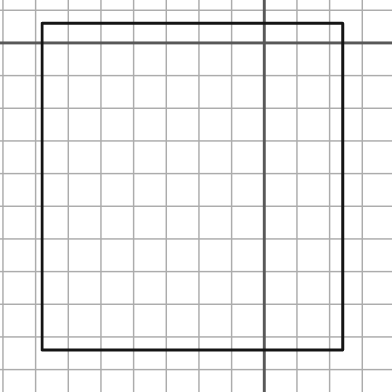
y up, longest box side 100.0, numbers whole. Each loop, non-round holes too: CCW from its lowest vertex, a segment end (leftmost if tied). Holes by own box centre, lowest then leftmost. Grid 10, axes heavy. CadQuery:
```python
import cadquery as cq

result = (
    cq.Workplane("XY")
    .moveTo(-68.0, -94.0)
    .lineTo(24.0, -94.0)
    .lineTo(24.0, 6.0)
    .lineTo(-68.0, 6.0)
    .close()
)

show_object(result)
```